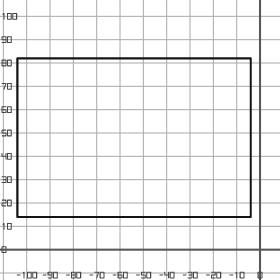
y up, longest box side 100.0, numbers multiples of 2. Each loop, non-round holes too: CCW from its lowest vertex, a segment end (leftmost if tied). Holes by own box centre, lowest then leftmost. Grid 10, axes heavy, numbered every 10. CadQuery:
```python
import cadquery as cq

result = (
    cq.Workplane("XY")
    .moveTo(-104.0, 14.0)
    .lineTo(-4.0, 14.0)
    .lineTo(-4.0, 82.0)
    .lineTo(-104.0, 82.0)
    .close()
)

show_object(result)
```